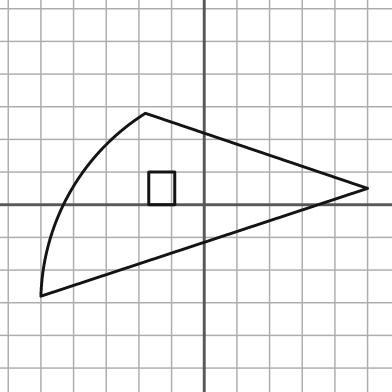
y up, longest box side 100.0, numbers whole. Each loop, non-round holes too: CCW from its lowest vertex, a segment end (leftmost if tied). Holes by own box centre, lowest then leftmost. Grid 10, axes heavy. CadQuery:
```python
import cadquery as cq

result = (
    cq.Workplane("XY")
    .moveTo(-50.0, -28.0)
    .lineTo(50.0, 5.0)
    .lineTo(-18.0, 28.0)
    .threePointArc((-41.0, 4.0), (-50.0, -28.0))
    .close()
    .moveTo(-17.0, 0.0)
    .lineTo(-9.0, 0.0)
    .lineTo(-9.0, 10.0)
    .lineTo(-17.0, 10.0)
    .close()
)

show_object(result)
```